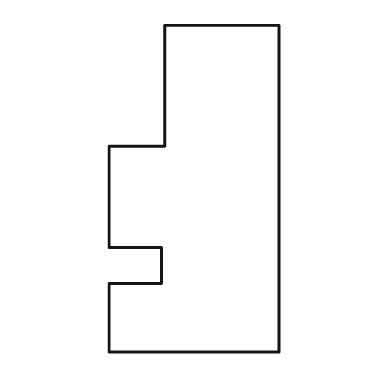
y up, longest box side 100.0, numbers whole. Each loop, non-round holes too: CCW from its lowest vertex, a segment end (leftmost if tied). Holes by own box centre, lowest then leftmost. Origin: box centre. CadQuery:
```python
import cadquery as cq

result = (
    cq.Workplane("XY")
    .moveTo(-26.0, -50.0)
    .lineTo(26.0, -50.0)
    .lineTo(26.0, 50.0)
    .lineTo(-9.0, 50.0)
    .lineTo(-9.0, 13.0)
    .lineTo(-26.0, 13.0)
    .lineTo(-26.0, -18.0)
    .lineTo(-10.0, -18.0)
    .lineTo(-10.0, -29.0)
    .lineTo(-26.0, -29.0)
    .close()
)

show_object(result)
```